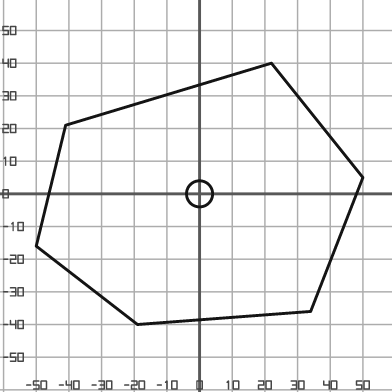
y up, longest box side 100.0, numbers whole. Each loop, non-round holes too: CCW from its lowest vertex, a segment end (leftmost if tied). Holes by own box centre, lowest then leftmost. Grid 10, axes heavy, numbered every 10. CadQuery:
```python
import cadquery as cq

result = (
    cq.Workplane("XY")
    .moveTo(-19.0, -40.0)
    .lineTo(34.0, -36.0)
    .lineTo(50.0, 5.0)
    .lineTo(22.0, 40.0)
    .lineTo(-41.0, 21.0)
    .lineTo(-50.0, -16.0)
    .close()
    .moveTo(0.0, 0.0)
    .circle(4.0)
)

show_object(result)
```